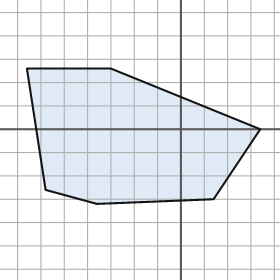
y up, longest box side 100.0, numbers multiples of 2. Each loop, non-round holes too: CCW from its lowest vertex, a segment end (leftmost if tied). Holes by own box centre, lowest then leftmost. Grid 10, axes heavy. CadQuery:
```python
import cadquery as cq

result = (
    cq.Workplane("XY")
    .moveTo(-36.0, -32.0)
    .lineTo(14.0, -30.0)
    .lineTo(34.0, 0.0)
    .lineTo(-30.0, 26.0)
    .lineTo(-66.0, 26.0)
    .lineTo(-58.0, -26.0)
    .close()
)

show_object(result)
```